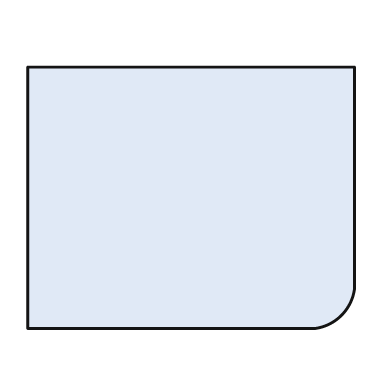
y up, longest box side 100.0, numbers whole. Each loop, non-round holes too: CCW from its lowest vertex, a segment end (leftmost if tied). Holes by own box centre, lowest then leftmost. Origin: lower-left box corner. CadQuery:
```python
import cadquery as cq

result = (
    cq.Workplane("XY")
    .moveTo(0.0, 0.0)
    .lineTo(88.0, 0.0)
    .threePointArc((96.0, 4.0), (100.0, 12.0))
    .lineTo(100.0, 80.0)
    .lineTo(0.0, 80.0)
    .close()
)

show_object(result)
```